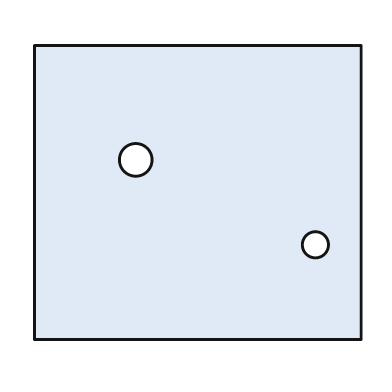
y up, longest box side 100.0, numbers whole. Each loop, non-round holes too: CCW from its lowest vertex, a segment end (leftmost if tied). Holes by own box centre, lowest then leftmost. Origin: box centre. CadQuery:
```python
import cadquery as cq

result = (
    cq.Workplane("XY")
    .moveTo(-50.0, -45.0)
    .lineTo(50.0, -45.0)
    .lineTo(50.0, 45.0)
    .lineTo(-50.0, 45.0)
    .close()
    .moveTo(36.0, -16.0)
    .circle(4.0)
    .moveTo(-19.0, 10.0)
    .circle(5.0)
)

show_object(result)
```